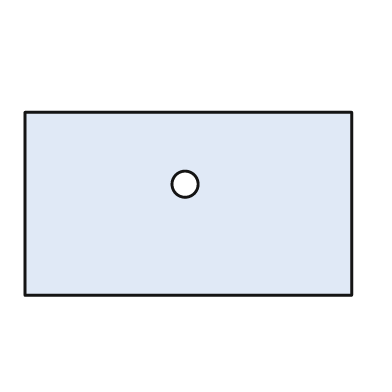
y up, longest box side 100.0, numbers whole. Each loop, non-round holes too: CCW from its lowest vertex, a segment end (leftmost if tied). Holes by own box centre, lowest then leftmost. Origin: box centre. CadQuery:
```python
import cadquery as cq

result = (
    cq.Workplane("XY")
    .moveTo(-50.0, -28.0)
    .lineTo(50.0, -28.0)
    .lineTo(50.0, 28.0)
    .lineTo(-50.0, 28.0)
    .close()
    .moveTo(-1.0, 6.0)
    .circle(4.0)
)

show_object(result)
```